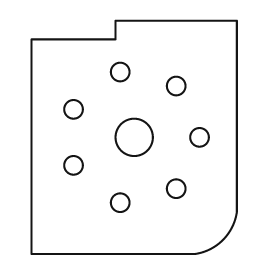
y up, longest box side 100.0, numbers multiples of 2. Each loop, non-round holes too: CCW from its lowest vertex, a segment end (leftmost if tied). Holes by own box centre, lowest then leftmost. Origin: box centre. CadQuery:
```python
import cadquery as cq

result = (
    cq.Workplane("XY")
    .moveTo(-44.0, -50.0)
    .lineTo(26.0, -50.0)
    .threePointArc((38.0, -44.0), (44.0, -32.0))
    .lineTo(44.0, 50.0)
    .lineTo(-8.0, 50.0)
    .lineTo(-8.0, 42.0)
    .lineTo(-44.0, 42.0)
    .close()
    .moveTo(-6.0, -28.0)
    .circle(4.0)
    .moveTo(18.0, -22.0)
    .circle(4.0)
    .moveTo(-26.0, -12.0)
    .circle(4.0)
    .moveTo(0.0, 0.0)
    .circle(8.0)
    .moveTo(28.0, 0.0)
    .circle(4.0)
    .moveTo(-26.0, 12.0)
    .circle(4.0)
    .moveTo(18.0, 22.0)
    .circle(4.0)
    .moveTo(-6.0, 28.0)
    .circle(4.0)
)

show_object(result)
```